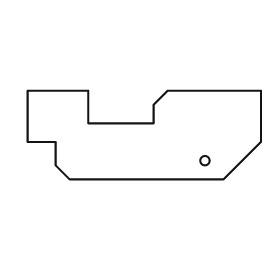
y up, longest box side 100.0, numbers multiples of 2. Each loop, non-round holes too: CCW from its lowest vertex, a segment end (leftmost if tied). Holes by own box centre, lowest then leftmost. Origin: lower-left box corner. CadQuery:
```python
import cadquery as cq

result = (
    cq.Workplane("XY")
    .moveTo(18.0, 0.0)
    .lineTo(84.0, 0.0)
    .lineTo(100.0, 16.0)
    .lineTo(100.0, 38.0)
    .lineTo(60.0, 38.0)
    .lineTo(54.0, 32.0)
    .lineTo(54.0, 24.0)
    .lineTo(26.0, 24.0)
    .lineTo(26.0, 38.0)
    .lineTo(0.0, 38.0)
    .lineTo(0.0, 16.0)
    .lineTo(12.0, 16.0)
    .lineTo(12.0, 6.0)
    .close()
    .moveTo(76.0, 8.0)
    .circle(2.0)
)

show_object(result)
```